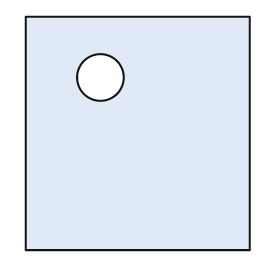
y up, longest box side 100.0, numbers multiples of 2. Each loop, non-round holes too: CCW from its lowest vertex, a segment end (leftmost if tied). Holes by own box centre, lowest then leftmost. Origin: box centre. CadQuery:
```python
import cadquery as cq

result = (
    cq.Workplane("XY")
    .moveTo(-48.0, -50.0)
    .lineTo(48.0, -50.0)
    .lineTo(48.0, 50.0)
    .lineTo(-48.0, 50.0)
    .close()
    .moveTo(-16.0, 24.0)
    .circle(10.0)
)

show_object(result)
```